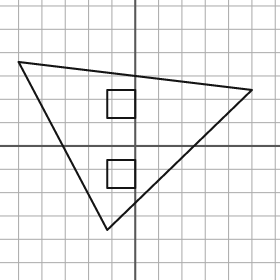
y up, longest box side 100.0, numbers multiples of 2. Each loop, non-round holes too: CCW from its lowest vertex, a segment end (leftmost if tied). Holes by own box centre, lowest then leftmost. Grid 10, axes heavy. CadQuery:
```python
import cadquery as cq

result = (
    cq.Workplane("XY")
    .moveTo(-12.0, -36.0)
    .lineTo(50.0, 24.0)
    .lineTo(-50.0, 36.0)
    .close()
    .moveTo(-12.0, -18.0)
    .lineTo(0.0, -18.0)
    .lineTo(0.0, -6.0)
    .lineTo(-12.0, -6.0)
    .close()
    .moveTo(-12.0, 12.0)
    .lineTo(0.0, 12.0)
    .lineTo(0.0, 24.0)
    .lineTo(-12.0, 24.0)
    .close()
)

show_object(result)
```